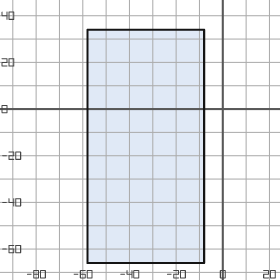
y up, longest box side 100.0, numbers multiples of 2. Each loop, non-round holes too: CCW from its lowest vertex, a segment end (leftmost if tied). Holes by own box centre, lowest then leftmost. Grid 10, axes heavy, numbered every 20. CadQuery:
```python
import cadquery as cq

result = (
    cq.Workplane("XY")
    .moveTo(-58.0, -66.0)
    .lineTo(-8.0, -66.0)
    .lineTo(-8.0, 34.0)
    .lineTo(-58.0, 34.0)
    .close()
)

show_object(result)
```